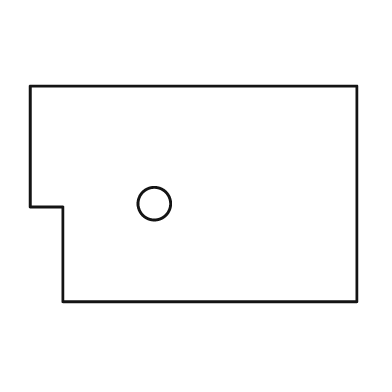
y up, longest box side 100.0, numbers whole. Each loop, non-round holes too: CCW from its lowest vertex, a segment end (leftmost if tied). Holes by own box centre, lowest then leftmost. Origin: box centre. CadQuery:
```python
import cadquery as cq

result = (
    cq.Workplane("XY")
    .moveTo(-40.0, -33.0)
    .lineTo(50.0, -33.0)
    .lineTo(50.0, 33.0)
    .lineTo(-50.0, 33.0)
    .lineTo(-50.0, -4.0)
    .lineTo(-40.0, -4.0)
    .close()
    .moveTo(-12.0, -3.0)
    .circle(5.0)
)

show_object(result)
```